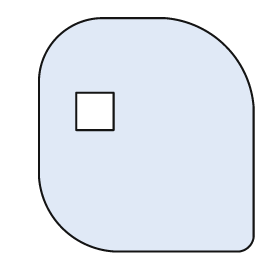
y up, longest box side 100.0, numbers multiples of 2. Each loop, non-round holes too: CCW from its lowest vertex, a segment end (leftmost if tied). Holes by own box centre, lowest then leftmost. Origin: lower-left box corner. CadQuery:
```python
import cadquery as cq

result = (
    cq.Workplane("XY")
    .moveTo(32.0, 0.0)
    .lineTo(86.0, 0.0)
    .threePointArc((90.0, 2.0), (92.0, 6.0))
    .lineTo(92.0, 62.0)
    .threePointArc((80.0, 88.0), (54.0, 100.0))
    .lineTo(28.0, 100.0)
    .threePointArc((8.0, 92.0), (0.0, 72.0))
    .lineTo(0.0, 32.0)
    .threePointArc((10.0, 10.0), (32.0, 0.0))
    .close()
    .moveTo(16.0, 52.0)
    .lineTo(32.0, 52.0)
    .lineTo(32.0, 68.0)
    .lineTo(16.0, 68.0)
    .close()
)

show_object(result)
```